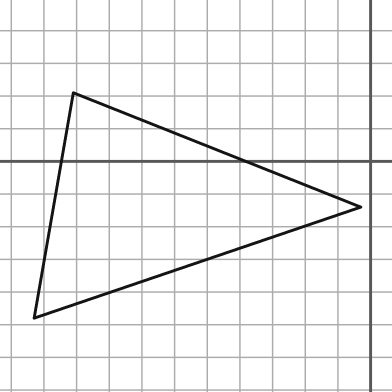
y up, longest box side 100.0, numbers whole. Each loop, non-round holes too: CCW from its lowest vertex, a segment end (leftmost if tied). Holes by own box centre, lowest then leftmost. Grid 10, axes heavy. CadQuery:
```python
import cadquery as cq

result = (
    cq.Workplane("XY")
    .moveTo(-103.0, -48.0)
    .lineTo(-3.0, -14.0)
    .lineTo(-91.0, 21.0)
    .close()
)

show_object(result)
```